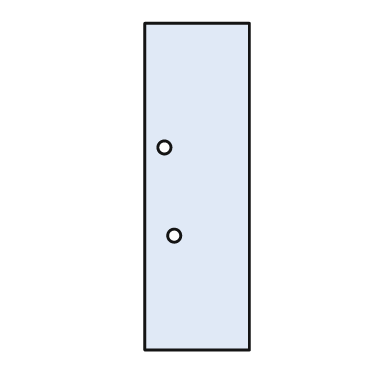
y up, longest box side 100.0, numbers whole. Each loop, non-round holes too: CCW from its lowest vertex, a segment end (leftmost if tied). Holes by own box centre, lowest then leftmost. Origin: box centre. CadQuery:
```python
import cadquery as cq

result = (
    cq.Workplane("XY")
    .moveTo(-16.0, -50.0)
    .lineTo(16.0, -50.0)
    .lineTo(16.0, 50.0)
    .lineTo(-16.0, 50.0)
    .close()
    .moveTo(-7.0, -15.0)
    .circle(2.0)
    .moveTo(-10.0, 12.0)
    .circle(2.0)
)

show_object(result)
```